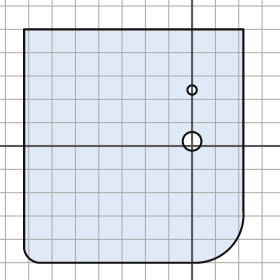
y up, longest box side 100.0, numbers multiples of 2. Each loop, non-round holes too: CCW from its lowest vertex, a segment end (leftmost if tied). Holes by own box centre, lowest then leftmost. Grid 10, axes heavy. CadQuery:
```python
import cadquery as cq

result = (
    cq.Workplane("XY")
    .moveTo(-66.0, -50.0)
    .lineTo(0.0, -50.0)
    .threePointArc((16.0, -44.0), (22.0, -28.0))
    .lineTo(22.0, 50.0)
    .lineTo(-72.0, 50.0)
    .lineTo(-72.0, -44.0)
    .threePointArc((-70.0, -48.0), (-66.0, -50.0))
    .close()
    .moveTo(0.0, 2.0)
    .circle(4.0)
    .moveTo(0.0, 24.0)
    .circle(2.0)
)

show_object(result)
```